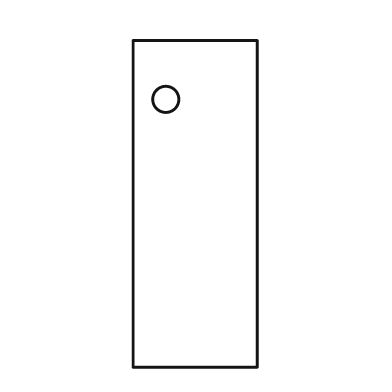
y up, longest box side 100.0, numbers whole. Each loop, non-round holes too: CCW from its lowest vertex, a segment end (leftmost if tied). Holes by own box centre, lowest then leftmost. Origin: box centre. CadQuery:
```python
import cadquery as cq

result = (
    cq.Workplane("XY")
    .moveTo(-19.0, -50.0)
    .lineTo(19.0, -50.0)
    .lineTo(19.0, 50.0)
    .lineTo(-19.0, 50.0)
    .close()
    .moveTo(-9.0, 32.0)
    .circle(4.0)
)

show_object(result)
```